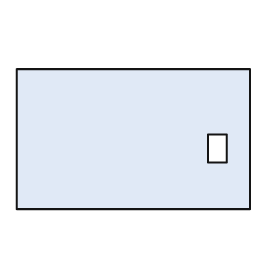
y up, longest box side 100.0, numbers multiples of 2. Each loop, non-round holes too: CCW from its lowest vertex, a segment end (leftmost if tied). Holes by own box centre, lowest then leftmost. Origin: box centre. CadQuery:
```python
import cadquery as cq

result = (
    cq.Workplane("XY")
    .moveTo(-50.0, -30.0)
    .lineTo(50.0, -30.0)
    .lineTo(50.0, 30.0)
    .lineTo(-50.0, 30.0)
    .close()
    .moveTo(32.0, -10.0)
    .lineTo(40.0, -10.0)
    .lineTo(40.0, 2.0)
    .lineTo(32.0, 2.0)
    .close()
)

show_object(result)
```